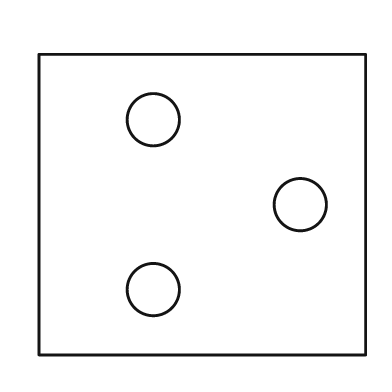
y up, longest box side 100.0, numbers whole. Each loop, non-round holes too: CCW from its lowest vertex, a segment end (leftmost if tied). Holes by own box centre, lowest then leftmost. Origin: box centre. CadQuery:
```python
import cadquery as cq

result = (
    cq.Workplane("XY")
    .moveTo(-50.0, -46.0)
    .lineTo(50.0, -46.0)
    .lineTo(50.0, 46.0)
    .lineTo(-50.0, 46.0)
    .close()
    .moveTo(-15.0, -26.0)
    .circle(8.0)
    .moveTo(30.0, 0.0)
    .circle(8.0)
    .moveTo(-15.0, 26.0)
    .circle(8.0)
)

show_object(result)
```